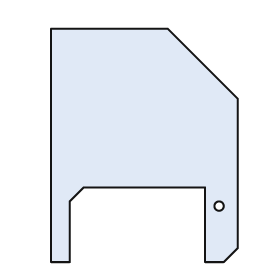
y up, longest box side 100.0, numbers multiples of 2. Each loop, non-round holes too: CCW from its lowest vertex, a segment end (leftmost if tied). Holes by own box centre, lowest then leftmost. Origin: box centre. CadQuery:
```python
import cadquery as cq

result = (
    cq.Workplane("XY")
    .moveTo(-40.0, -50.0)
    .lineTo(-32.0, -50.0)
    .lineTo(-32.0, -24.0)
    .lineTo(-26.0, -18.0)
    .lineTo(26.0, -18.0)
    .lineTo(26.0, -50.0)
    .lineTo(34.0, -50.0)
    .lineTo(40.0, -44.0)
    .lineTo(40.0, 20.0)
    .lineTo(10.0, 50.0)
    .lineTo(-40.0, 50.0)
    .close()
    .moveTo(32.0, -26.0)
    .circle(2.0)
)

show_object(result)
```